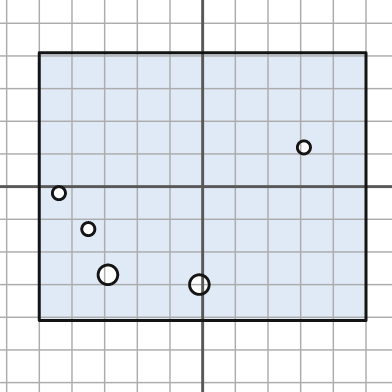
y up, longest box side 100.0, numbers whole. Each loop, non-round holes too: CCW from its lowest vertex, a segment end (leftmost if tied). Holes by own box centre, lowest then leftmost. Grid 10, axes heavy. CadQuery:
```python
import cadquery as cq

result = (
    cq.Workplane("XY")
    .moveTo(-50.0, -41.0)
    .lineTo(50.0, -41.0)
    .lineTo(50.0, 41.0)
    .lineTo(-50.0, 41.0)
    .close()
    .moveTo(-1.0, -30.0)
    .circle(3.0)
    .moveTo(-29.0, -27.0)
    .circle(3.0)
    .moveTo(-35.0, -13.0)
    .circle(2.0)
    .moveTo(-44.0, -2.0)
    .circle(2.0)
    .moveTo(31.0, 12.0)
    .circle(2.0)
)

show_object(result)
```